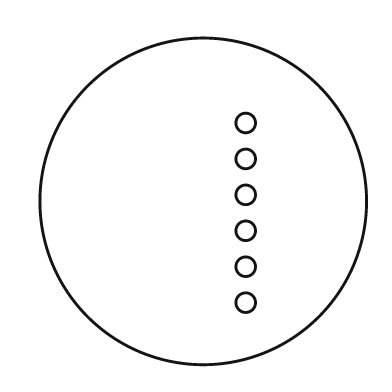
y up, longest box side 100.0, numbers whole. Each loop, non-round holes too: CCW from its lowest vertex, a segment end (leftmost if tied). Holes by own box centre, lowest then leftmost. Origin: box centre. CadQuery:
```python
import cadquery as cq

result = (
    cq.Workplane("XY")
    .moveTo(0.0, 0.0)
    .circle(50.0)
    .moveTo(13.0, -31.0)
    .circle(3.0)
    .moveTo(13.0, -20.0)
    .circle(3.0)
    .moveTo(13.0, -9.0)
    .circle(3.0)
    .moveTo(13.0, 2.0)
    .circle(3.0)
    .moveTo(13.0, 13.0)
    .circle(3.0)
    .moveTo(13.0, 24.0)
    .circle(3.0)
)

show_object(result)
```